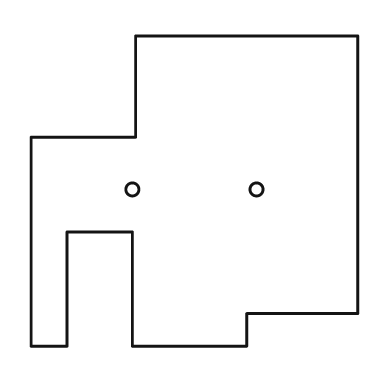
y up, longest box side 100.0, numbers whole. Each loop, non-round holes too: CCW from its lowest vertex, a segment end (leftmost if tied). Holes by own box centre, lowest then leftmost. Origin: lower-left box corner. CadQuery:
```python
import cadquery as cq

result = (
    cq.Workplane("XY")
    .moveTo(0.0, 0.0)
    .lineTo(11.0, 0.0)
    .lineTo(11.0, 35.0)
    .lineTo(31.0, 35.0)
    .lineTo(31.0, 0.0)
    .lineTo(66.0, 0.0)
    .lineTo(66.0, 10.0)
    .lineTo(100.0, 10.0)
    .lineTo(100.0, 95.0)
    .lineTo(32.0, 95.0)
    .lineTo(32.0, 64.0)
    .lineTo(0.0, 64.0)
    .close()
    .moveTo(31.0, 48.0)
    .circle(2.0)
    .moveTo(69.0, 48.0)
    .circle(2.0)
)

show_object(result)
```